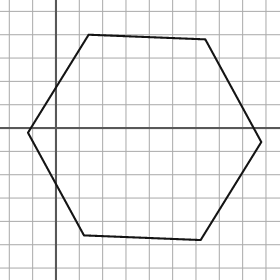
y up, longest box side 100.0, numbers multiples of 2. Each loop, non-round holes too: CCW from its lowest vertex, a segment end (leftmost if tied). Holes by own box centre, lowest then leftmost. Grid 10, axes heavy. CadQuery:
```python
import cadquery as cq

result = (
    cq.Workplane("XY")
    .moveTo(62.0, -48.0)
    .lineTo(88.0, -6.0)
    .lineTo(64.0, 38.0)
    .lineTo(14.0, 40.0)
    .lineTo(-12.0, -2.0)
    .lineTo(12.0, -46.0)
    .close()
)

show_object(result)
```